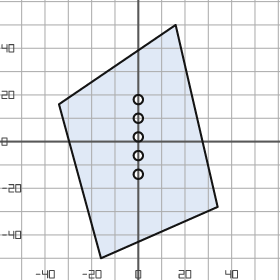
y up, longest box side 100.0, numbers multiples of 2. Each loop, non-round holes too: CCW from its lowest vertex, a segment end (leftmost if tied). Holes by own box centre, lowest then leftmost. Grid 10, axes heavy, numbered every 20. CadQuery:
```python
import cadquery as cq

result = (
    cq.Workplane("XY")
    .moveTo(-16.0, -50.0)
    .lineTo(34.0, -28.0)
    .lineTo(16.0, 50.0)
    .lineTo(-34.0, 16.0)
    .close()
    .moveTo(0.0, -14.0)
    .circle(2.0)
    .moveTo(0.0, -6.0)
    .circle(2.0)
    .moveTo(0.0, 2.0)
    .circle(2.0)
    .moveTo(0.0, 10.0)
    .circle(2.0)
    .moveTo(0.0, 18.0)
    .circle(2.0)
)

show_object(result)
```